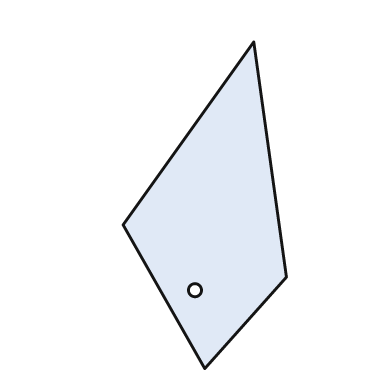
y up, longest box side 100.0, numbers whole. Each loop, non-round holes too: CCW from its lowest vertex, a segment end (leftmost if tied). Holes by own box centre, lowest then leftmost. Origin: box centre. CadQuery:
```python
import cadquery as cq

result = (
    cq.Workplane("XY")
    .moveTo(0.0, -50.0)
    .lineTo(25.0, -22.0)
    .lineTo(15.0, 50.0)
    .lineTo(-25.0, -6.0)
    .close()
    .moveTo(-3.0, -26.0)
    .circle(2.0)
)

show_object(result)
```